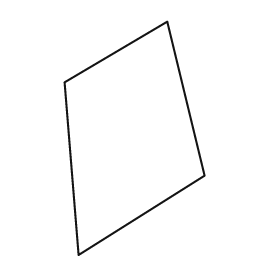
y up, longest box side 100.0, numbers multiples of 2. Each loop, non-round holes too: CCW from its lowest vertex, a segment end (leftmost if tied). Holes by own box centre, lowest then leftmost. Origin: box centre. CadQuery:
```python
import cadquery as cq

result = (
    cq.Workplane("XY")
    .moveTo(-24.0, -50.0)
    .lineTo(30.0, -16.0)
    .lineTo(14.0, 50.0)
    .lineTo(-30.0, 24.0)
    .close()
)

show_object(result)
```